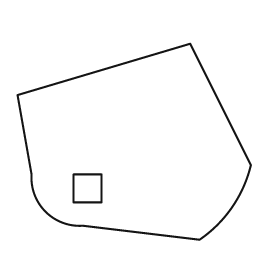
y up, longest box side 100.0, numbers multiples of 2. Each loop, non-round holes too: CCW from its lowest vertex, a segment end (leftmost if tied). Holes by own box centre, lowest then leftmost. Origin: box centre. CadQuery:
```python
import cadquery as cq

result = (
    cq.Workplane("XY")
    .moveTo(28.0, -42.0)
    .threePointArc((42.0, -28.0), (50.0, -10.0))
    .lineTo(24.0, 42.0)
    .lineTo(-50.0, 20.0)
    .lineTo(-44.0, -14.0)
    .threePointArc((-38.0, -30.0), (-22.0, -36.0))
    .close()
    .moveTo(-26.0, -26.0)
    .lineTo(-14.0, -26.0)
    .lineTo(-14.0, -14.0)
    .lineTo(-26.0, -14.0)
    .close()
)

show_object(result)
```